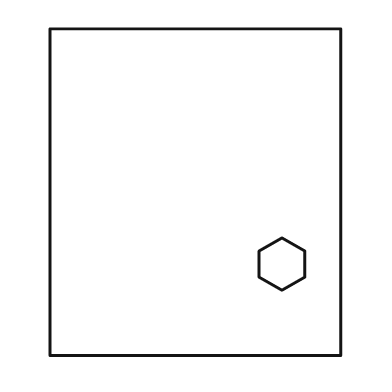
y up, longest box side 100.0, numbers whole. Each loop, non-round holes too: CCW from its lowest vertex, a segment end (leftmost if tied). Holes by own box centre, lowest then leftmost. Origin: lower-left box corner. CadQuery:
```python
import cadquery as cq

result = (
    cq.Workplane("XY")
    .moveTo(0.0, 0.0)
    .lineTo(89.0, 0.0)
    .lineTo(89.0, 100.0)
    .lineTo(0.0, 100.0)
    .close()
    .moveTo(71.0, 20.0)
    .lineTo(78.0, 24.0)
    .lineTo(78.0, 32.0)
    .lineTo(71.0, 36.0)
    .lineTo(64.0, 32.0)
    .lineTo(64.0, 24.0)
    .close()
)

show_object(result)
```